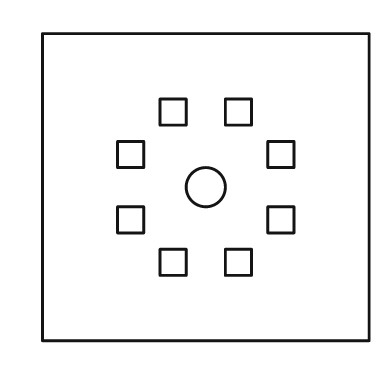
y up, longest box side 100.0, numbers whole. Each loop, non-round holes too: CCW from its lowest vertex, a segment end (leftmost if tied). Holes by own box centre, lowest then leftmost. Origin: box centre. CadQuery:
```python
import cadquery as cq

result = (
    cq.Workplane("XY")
    .moveTo(-50.0, -47.0)
    .lineTo(50.0, -47.0)
    .lineTo(50.0, 47.0)
    .lineTo(-50.0, 47.0)
    .close()
    .moveTo(-14.0, -27.0)
    .lineTo(-6.0, -27.0)
    .lineTo(-6.0, -19.0)
    .lineTo(-14.0, -19.0)
    .close()
    .moveTo(6.0, -27.0)
    .lineTo(14.0, -27.0)
    .lineTo(14.0, -19.0)
    .lineTo(6.0, -19.0)
    .close()
    .moveTo(-27.0, -14.0)
    .lineTo(-19.0, -14.0)
    .lineTo(-19.0, -6.0)
    .lineTo(-27.0, -6.0)
    .close()
    .moveTo(19.0, -14.0)
    .lineTo(27.0, -14.0)
    .lineTo(27.0, -6.0)
    .lineTo(19.0, -6.0)
    .close()
    .moveTo(0.0, 0.0)
    .circle(6.0)
    .moveTo(-27.0, 6.0)
    .lineTo(-19.0, 6.0)
    .lineTo(-19.0, 14.0)
    .lineTo(-27.0, 14.0)
    .close()
    .moveTo(19.0, 6.0)
    .lineTo(27.0, 6.0)
    .lineTo(27.0, 14.0)
    .lineTo(19.0, 14.0)
    .close()
    .moveTo(-14.0, 19.0)
    .lineTo(-6.0, 19.0)
    .lineTo(-6.0, 27.0)
    .lineTo(-14.0, 27.0)
    .close()
    .moveTo(6.0, 19.0)
    .lineTo(14.0, 19.0)
    .lineTo(14.0, 27.0)
    .lineTo(6.0, 27.0)
    .close()
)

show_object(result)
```